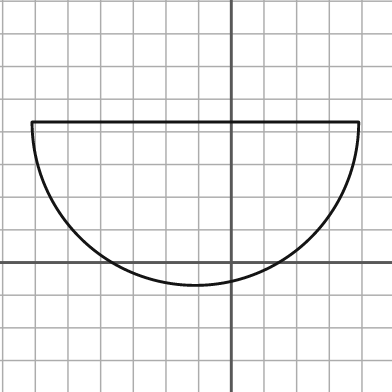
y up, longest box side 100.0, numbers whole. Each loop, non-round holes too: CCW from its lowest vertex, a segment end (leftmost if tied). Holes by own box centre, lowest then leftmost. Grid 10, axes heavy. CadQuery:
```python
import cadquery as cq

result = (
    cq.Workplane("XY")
    .moveTo(-61.0, 43.0)
    .threePointArc((-11.0, -7.0), (39.0, 43.0))
    .close()
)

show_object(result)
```